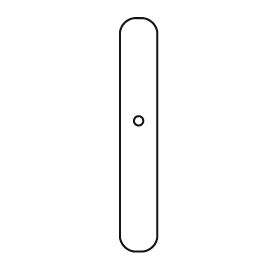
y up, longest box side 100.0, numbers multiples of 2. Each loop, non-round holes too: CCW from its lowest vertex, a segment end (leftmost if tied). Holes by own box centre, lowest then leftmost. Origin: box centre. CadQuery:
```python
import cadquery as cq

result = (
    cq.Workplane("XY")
    .moveTo(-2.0, -50.0)
    .lineTo(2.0, -50.0)
    .threePointArc((6.0, -48.0), (8.0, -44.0))
    .lineTo(8.0, 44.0)
    .threePointArc((6.0, 48.0), (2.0, 50.0))
    .lineTo(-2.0, 50.0)
    .threePointArc((-6.0, 48.0), (-8.0, 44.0))
    .lineTo(-8.0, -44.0)
    .threePointArc((-6.0, -48.0), (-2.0, -50.0))
    .close()
    .moveTo(0.0, 6.0)
    .circle(2.0)
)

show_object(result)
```